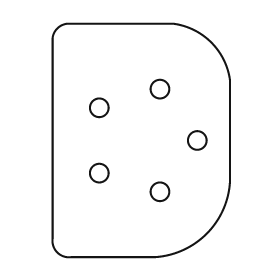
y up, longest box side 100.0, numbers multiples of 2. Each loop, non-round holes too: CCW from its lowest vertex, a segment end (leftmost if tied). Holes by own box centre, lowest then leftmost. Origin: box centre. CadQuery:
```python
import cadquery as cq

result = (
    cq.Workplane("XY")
    .moveTo(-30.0, -50.0)
    .lineTo(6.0, -50.0)
    .threePointArc((28.0, -40.0), (38.0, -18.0))
    .lineTo(38.0, 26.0)
    .threePointArc((30.0, 42.0), (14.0, 50.0))
    .lineTo(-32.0, 50.0)
    .threePointArc((-36.0, 48.0), (-38.0, 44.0))
    .lineTo(-38.0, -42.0)
    .threePointArc((-36.0, -48.0), (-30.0, -50.0))
    .close()
    .moveTo(8.0, -22.0)
    .circle(4.0)
    .moveTo(-18.0, -14.0)
    .circle(4.0)
    .moveTo(24.0, 0.0)
    .circle(4.0)
    .moveTo(-18.0, 14.0)
    .circle(4.0)
    .moveTo(8.0, 22.0)
    .circle(4.0)
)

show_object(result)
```